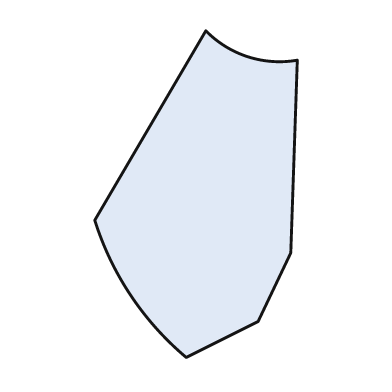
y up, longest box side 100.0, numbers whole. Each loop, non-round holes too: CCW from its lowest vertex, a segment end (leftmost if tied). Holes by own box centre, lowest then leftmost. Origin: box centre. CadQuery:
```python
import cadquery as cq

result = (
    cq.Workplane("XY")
    .moveTo(-3.0, -50.0)
    .lineTo(19.0, -39.0)
    .lineTo(29.0, -18.0)
    .lineTo(31.0, 41.0)
    .threePointArc((16.0, 42.0), (3.0, 50.0))
    .lineTo(-31.0, -8.0)
    .threePointArc((-20.0, -31.0), (-3.0, -50.0))
    .close()
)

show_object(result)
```